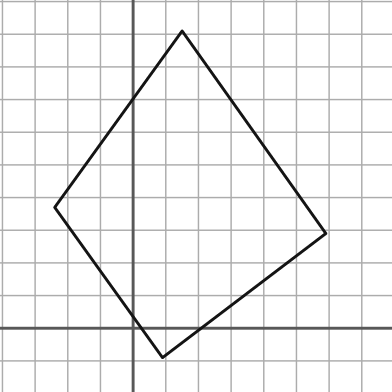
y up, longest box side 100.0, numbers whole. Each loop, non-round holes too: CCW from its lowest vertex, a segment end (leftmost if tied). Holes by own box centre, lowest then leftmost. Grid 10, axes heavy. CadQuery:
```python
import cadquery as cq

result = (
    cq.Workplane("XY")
    .moveTo(9.0, -9.0)
    .lineTo(59.0, 29.0)
    .lineTo(15.0, 91.0)
    .lineTo(-24.0, 37.0)
    .close()
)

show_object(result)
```